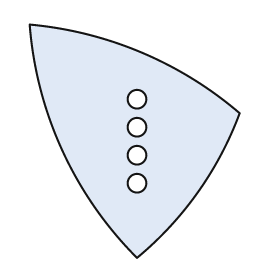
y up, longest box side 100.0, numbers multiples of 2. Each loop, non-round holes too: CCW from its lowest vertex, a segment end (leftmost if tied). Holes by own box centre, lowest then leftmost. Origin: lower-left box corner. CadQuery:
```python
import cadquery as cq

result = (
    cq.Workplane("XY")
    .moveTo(46.0, 0.0)
    .threePointArc((72.0, 28.0), (90.0, 62.0))
    .threePointArc((48.0, 88.0), (0.0, 100.0))
    .threePointArc((14.0, 46.0), (46.0, 0.0))
    .close()
    .moveTo(46.0, 32.0)
    .circle(4.0)
    .moveTo(46.0, 44.0)
    .circle(4.0)
    .moveTo(46.0, 56.0)
    .circle(4.0)
    .moveTo(46.0, 68.0)
    .circle(4.0)
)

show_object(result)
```